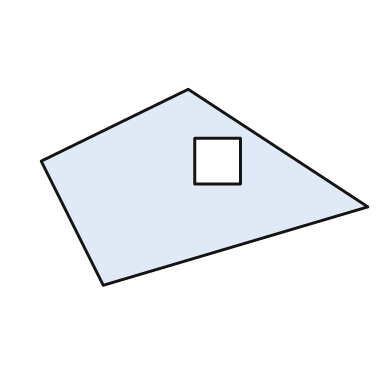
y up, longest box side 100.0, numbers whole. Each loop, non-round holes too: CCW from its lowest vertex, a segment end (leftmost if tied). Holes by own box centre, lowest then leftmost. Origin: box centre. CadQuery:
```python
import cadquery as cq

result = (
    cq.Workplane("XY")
    .moveTo(-31.0, -30.0)
    .lineTo(50.0, -6.0)
    .lineTo(-5.0, 30.0)
    .lineTo(-50.0, 8.0)
    .close()
    .moveTo(-3.0, 1.0)
    .lineTo(11.0, 1.0)
    .lineTo(11.0, 15.0)
    .lineTo(-3.0, 15.0)
    .close()
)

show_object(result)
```